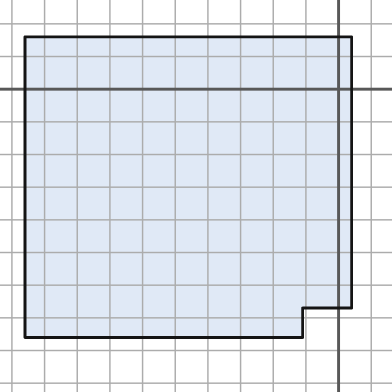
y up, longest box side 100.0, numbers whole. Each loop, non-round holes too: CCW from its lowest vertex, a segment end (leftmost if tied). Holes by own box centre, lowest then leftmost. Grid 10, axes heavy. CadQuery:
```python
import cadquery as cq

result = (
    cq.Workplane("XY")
    .moveTo(-96.0, -76.0)
    .lineTo(-11.0, -76.0)
    .lineTo(-11.0, -67.0)
    .lineTo(4.0, -67.0)
    .lineTo(4.0, 16.0)
    .lineTo(-96.0, 16.0)
    .close()
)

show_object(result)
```